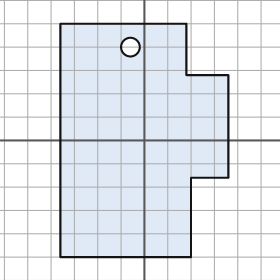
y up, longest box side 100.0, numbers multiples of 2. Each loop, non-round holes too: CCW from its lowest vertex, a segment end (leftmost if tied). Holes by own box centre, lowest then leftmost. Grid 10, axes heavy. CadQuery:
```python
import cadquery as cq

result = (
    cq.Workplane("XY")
    .moveTo(-36.0, -50.0)
    .lineTo(20.0, -50.0)
    .lineTo(20.0, -16.0)
    .lineTo(36.0, -16.0)
    .lineTo(36.0, 28.0)
    .lineTo(18.0, 28.0)
    .lineTo(18.0, 50.0)
    .lineTo(-36.0, 50.0)
    .close()
    .moveTo(-6.0, 40.0)
    .circle(4.0)
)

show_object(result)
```